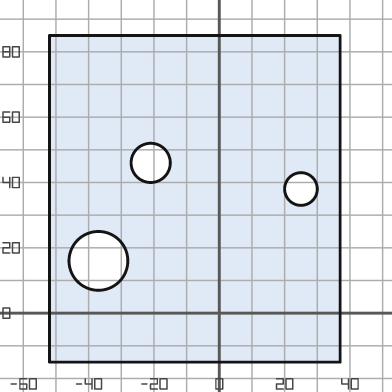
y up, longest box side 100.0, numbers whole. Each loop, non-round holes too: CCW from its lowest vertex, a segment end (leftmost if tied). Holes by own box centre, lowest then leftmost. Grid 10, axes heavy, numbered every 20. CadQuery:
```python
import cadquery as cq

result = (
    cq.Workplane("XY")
    .moveTo(-52.0, -15.0)
    .lineTo(37.0, -15.0)
    .lineTo(37.0, 85.0)
    .lineTo(-52.0, 85.0)
    .close()
    .moveTo(-37.0, 16.0)
    .circle(9.0)
    .moveTo(25.0, 38.0)
    .circle(5.0)
    .moveTo(-21.0, 46.0)
    .circle(6.0)
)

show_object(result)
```